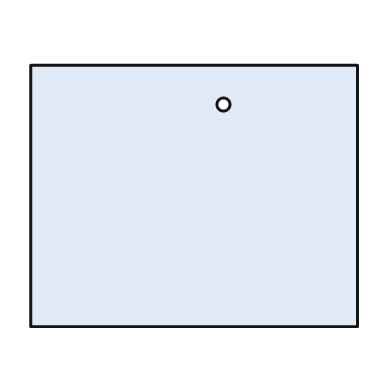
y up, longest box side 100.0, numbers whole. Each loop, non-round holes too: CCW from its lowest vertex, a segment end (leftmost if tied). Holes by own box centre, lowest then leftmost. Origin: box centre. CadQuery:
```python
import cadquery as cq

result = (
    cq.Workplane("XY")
    .moveTo(-50.0, -40.0)
    .lineTo(50.0, -40.0)
    .lineTo(50.0, 40.0)
    .lineTo(-50.0, 40.0)
    .close()
    .moveTo(9.0, 28.0)
    .circle(2.0)
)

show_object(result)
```